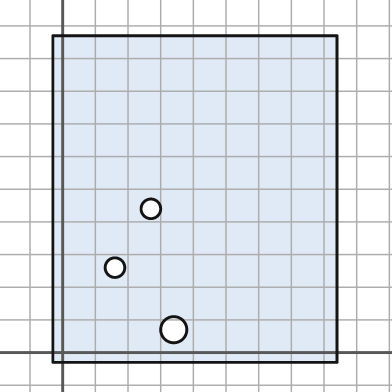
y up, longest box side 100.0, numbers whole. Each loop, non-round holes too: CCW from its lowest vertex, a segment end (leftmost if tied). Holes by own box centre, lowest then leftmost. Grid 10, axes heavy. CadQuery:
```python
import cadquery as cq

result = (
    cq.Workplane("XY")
    .moveTo(-3.0, -3.0)
    .lineTo(84.0, -3.0)
    .lineTo(84.0, 97.0)
    .lineTo(-3.0, 97.0)
    .close()
    .moveTo(34.0, 7.0)
    .circle(4.0)
    .moveTo(16.0, 26.0)
    .circle(3.0)
    .moveTo(27.0, 44.0)
    .circle(3.0)
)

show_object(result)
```